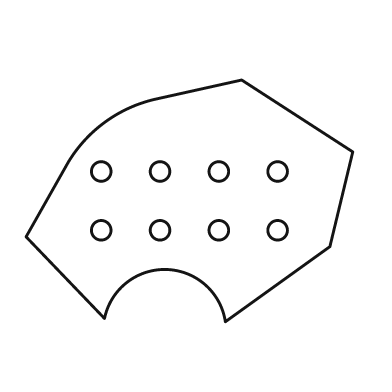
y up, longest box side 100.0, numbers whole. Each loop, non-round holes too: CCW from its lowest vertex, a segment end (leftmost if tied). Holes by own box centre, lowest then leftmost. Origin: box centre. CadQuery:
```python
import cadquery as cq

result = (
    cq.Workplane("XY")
    .moveTo(11.0, -37.0)
    .lineTo(43.0, -14.0)
    .lineTo(50.0, 15.0)
    .lineTo(16.0, 37.0)
    .lineTo(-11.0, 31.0)
    .threePointArc((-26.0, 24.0), (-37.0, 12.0))
    .lineTo(-50.0, -11.0)
    .lineTo(-26.0, -36.0)
    .threePointArc((-7.0, -21.0), (11.0, -37.0))
    .close()
    .moveTo(-27.0, -9.0)
    .circle(3.0)
    .moveTo(-9.0, -9.0)
    .circle(3.0)
    .moveTo(9.0, -9.0)
    .circle(3.0)
    .moveTo(27.0, -9.0)
    .circle(3.0)
    .moveTo(-27.0, 9.0)
    .circle(3.0)
    .moveTo(-9.0, 9.0)
    .circle(3.0)
    .moveTo(9.0, 9.0)
    .circle(3.0)
    .moveTo(27.0, 9.0)
    .circle(3.0)
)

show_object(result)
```